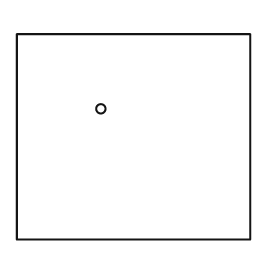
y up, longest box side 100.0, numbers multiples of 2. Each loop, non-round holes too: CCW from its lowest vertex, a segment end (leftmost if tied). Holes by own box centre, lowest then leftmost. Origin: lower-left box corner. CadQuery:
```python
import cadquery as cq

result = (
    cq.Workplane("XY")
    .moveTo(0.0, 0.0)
    .lineTo(100.0, 0.0)
    .lineTo(100.0, 88.0)
    .lineTo(0.0, 88.0)
    .close()
    .moveTo(36.0, 56.0)
    .circle(2.0)
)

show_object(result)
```